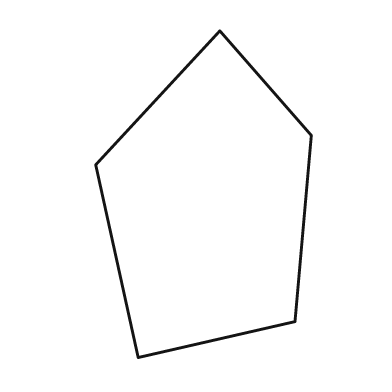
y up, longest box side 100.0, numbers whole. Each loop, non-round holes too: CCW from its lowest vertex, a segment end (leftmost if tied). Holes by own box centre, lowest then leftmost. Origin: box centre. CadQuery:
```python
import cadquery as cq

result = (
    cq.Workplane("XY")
    .moveTo(-20.0, -50.0)
    .lineTo(28.0, -39.0)
    .lineTo(33.0, 18.0)
    .lineTo(5.0, 50.0)
    .lineTo(-33.0, 9.0)
    .close()
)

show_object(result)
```